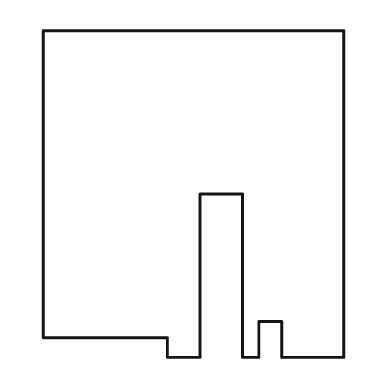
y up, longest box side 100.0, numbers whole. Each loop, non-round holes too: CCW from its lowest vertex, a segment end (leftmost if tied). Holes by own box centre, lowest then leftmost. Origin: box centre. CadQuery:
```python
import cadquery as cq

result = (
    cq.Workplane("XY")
    .moveTo(-8.0, -50.0)
    .lineTo(2.0, -50.0)
    .lineTo(2.0, 0.0)
    .lineTo(15.0, 0.0)
    .lineTo(15.0, -50.0)
    .lineTo(20.0, -50.0)
    .lineTo(20.0, -39.0)
    .lineTo(27.0, -39.0)
    .lineTo(27.0, -50.0)
    .lineTo(46.0, -50.0)
    .lineTo(46.0, 50.0)
    .lineTo(-46.0, 50.0)
    .lineTo(-46.0, -44.0)
    .lineTo(-8.0, -44.0)
    .close()
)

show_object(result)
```